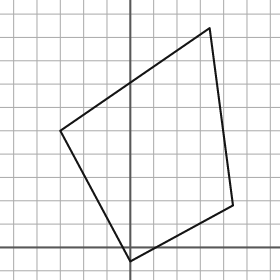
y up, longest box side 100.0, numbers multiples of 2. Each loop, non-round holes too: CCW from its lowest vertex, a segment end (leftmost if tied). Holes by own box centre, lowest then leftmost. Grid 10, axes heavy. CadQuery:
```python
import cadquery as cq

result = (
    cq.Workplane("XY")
    .moveTo(0.0, -6.0)
    .lineTo(44.0, 18.0)
    .lineTo(34.0, 94.0)
    .lineTo(-30.0, 50.0)
    .close()
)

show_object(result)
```